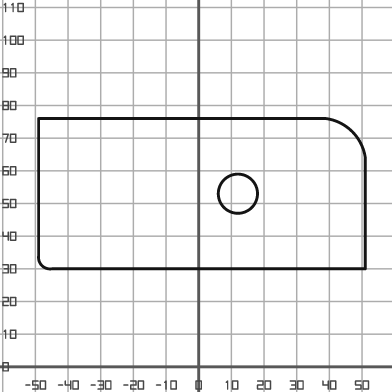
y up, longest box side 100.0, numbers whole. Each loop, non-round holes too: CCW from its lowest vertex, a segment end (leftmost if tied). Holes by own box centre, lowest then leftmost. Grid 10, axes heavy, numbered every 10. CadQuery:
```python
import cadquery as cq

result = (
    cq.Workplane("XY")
    .moveTo(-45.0, 30.0)
    .lineTo(51.0, 30.0)
    .lineTo(51.0, 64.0)
    .threePointArc((47.0, 72.0), (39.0, 76.0))
    .lineTo(-49.0, 76.0)
    .lineTo(-49.0, 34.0)
    .threePointArc((-48.0, 31.0), (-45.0, 30.0))
    .close()
    .moveTo(12.0, 53.0)
    .circle(6.0)
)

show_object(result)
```